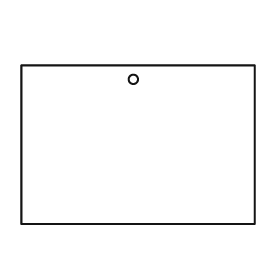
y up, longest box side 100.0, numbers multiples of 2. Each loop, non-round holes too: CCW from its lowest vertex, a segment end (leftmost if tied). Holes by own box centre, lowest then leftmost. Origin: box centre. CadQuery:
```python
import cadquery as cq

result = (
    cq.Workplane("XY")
    .moveTo(-50.0, -34.0)
    .lineTo(50.0, -34.0)
    .lineTo(50.0, 34.0)
    .lineTo(-50.0, 34.0)
    .close()
    .moveTo(-2.0, 28.0)
    .circle(2.0)
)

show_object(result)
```